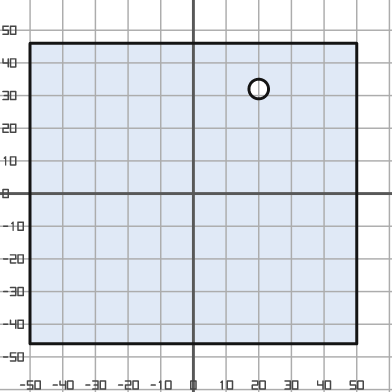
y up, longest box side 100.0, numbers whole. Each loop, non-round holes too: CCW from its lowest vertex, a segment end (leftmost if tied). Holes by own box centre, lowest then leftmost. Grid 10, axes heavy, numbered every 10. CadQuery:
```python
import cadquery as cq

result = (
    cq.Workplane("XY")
    .moveTo(-50.0, -46.0)
    .lineTo(50.0, -46.0)
    .lineTo(50.0, 46.0)
    .lineTo(-50.0, 46.0)
    .close()
    .moveTo(20.0, 32.0)
    .circle(3.0)
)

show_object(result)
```